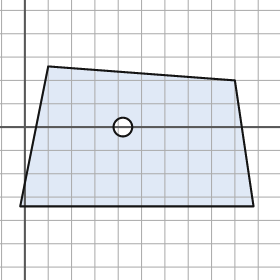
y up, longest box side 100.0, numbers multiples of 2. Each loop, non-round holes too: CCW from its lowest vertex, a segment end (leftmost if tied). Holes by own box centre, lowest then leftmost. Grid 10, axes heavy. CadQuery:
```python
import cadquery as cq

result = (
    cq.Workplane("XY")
    .moveTo(-2.0, -34.0)
    .lineTo(98.0, -34.0)
    .lineTo(90.0, 20.0)
    .lineTo(10.0, 26.0)
    .close()
    .moveTo(42.0, 0.0)
    .circle(4.0)
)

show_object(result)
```